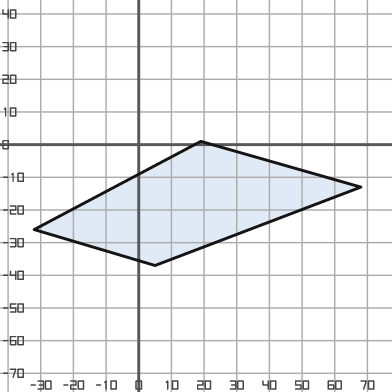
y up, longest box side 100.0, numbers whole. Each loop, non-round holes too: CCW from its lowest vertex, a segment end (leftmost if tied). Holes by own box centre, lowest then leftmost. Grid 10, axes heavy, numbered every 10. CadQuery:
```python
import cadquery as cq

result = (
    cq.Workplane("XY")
    .moveTo(5.0, -37.0)
    .lineTo(68.0, -13.0)
    .lineTo(19.0, 1.0)
    .lineTo(-32.0, -26.0)
    .close()
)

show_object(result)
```